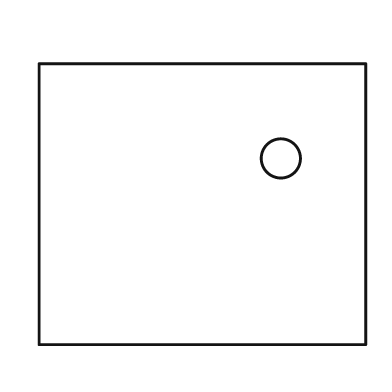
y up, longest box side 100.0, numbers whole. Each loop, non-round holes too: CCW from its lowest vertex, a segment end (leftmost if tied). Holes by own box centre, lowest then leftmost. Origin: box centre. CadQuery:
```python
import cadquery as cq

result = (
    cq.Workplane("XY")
    .moveTo(-50.0, -43.0)
    .lineTo(50.0, -43.0)
    .lineTo(50.0, 43.0)
    .lineTo(-50.0, 43.0)
    .close()
    .moveTo(24.0, 14.0)
    .circle(6.0)
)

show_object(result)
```